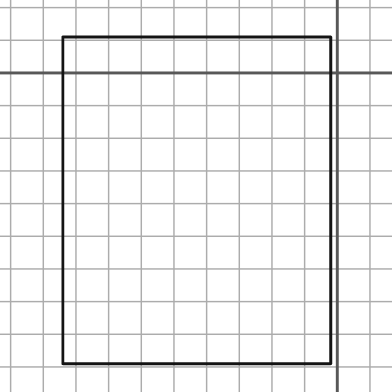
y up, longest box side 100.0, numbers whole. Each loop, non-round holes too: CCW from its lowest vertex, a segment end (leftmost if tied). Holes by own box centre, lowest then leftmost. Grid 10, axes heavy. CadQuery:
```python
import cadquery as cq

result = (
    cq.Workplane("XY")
    .moveTo(-84.0, -89.0)
    .lineTo(-2.0, -89.0)
    .lineTo(-2.0, 11.0)
    .lineTo(-84.0, 11.0)
    .close()
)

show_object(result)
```